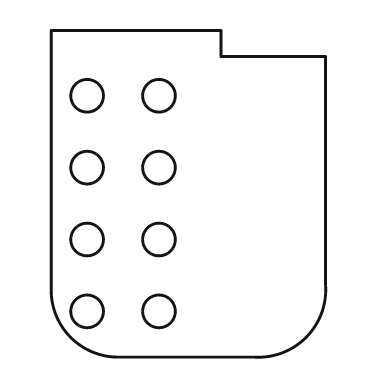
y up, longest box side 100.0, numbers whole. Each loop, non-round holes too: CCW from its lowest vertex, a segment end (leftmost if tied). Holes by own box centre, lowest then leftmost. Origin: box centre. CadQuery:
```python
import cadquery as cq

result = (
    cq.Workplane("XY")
    .moveTo(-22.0, -50.0)
    .lineTo(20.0, -50.0)
    .threePointArc((36.0, -44.0), (42.0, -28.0))
    .lineTo(42.0, 42.0)
    .lineTo(10.0, 42.0)
    .lineTo(10.0, 50.0)
    .lineTo(-42.0, 50.0)
    .lineTo(-42.0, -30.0)
    .threePointArc((-36.0, -44.0), (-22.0, -50.0))
    .close()
    .moveTo(-31.0, -36.0)
    .circle(5.0)
    .moveTo(-9.0, -36.0)
    .circle(5.0)
    .moveTo(-31.0, -14.0)
    .circle(5.0)
    .moveTo(-9.0, -14.0)
    .circle(5.0)
    .moveTo(-31.0, 8.0)
    .circle(5.0)
    .moveTo(-9.0, 8.0)
    .circle(5.0)
    .moveTo(-31.0, 30.0)
    .circle(5.0)
    .moveTo(-9.0, 30.0)
    .circle(5.0)
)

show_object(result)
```